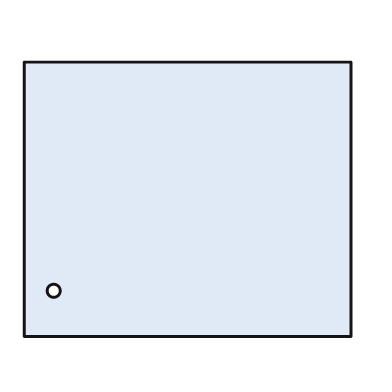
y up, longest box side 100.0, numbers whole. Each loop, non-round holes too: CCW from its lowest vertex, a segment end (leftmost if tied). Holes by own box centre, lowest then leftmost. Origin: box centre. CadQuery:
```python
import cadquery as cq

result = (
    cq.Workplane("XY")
    .moveTo(-50.0, -42.0)
    .lineTo(50.0, -42.0)
    .lineTo(50.0, 42.0)
    .lineTo(-50.0, 42.0)
    .close()
    .moveTo(-41.0, -28.0)
    .circle(2.0)
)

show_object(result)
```